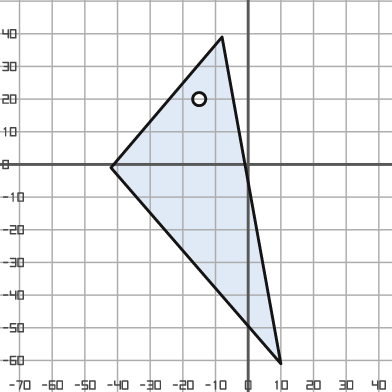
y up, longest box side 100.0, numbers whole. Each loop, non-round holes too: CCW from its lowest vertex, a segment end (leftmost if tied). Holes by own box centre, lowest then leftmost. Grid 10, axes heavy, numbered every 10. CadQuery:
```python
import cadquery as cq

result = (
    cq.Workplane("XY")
    .moveTo(10.0, -61.0)
    .lineTo(-8.0, 39.0)
    .lineTo(-42.0, -1.0)
    .close()
    .moveTo(-15.0, 20.0)
    .circle(2.0)
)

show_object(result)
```